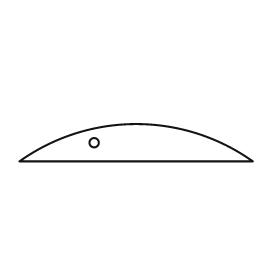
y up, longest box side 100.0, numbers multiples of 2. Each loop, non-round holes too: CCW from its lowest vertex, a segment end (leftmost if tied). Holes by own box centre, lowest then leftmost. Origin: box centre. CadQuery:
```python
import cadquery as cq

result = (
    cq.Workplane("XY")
    .moveTo(-50.0, -8.0)
    .lineTo(50.0, -8.0)
    .threePointArc((0.0, 8.0), (-50.0, -8.0))
    .close()
    .moveTo(-18.0, 0.0)
    .circle(2.0)
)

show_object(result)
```